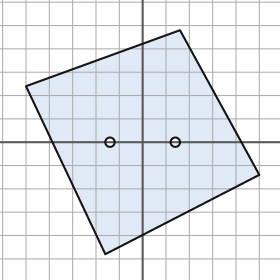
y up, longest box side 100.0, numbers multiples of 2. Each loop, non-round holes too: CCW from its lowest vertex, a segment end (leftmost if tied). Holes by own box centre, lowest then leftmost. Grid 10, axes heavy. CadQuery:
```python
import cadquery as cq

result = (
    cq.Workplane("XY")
    .moveTo(-16.0, -48.0)
    .lineTo(50.0, -14.0)
    .lineTo(16.0, 48.0)
    .lineTo(-50.0, 24.0)
    .close()
    .moveTo(-14.0, 0.0)
    .circle(2.0)
    .moveTo(14.0, 0.0)
    .circle(2.0)
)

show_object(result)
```